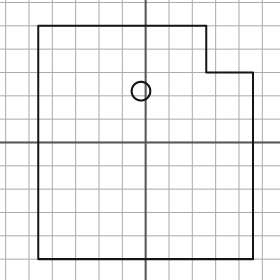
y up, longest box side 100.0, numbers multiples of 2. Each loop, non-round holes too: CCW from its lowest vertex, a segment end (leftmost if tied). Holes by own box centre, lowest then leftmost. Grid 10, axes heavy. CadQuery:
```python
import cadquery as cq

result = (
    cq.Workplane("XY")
    .moveTo(-46.0, -50.0)
    .lineTo(46.0, -50.0)
    .lineTo(46.0, 30.0)
    .lineTo(26.0, 30.0)
    .lineTo(26.0, 50.0)
    .lineTo(-46.0, 50.0)
    .close()
    .moveTo(-2.0, 22.0)
    .circle(4.0)
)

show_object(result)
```